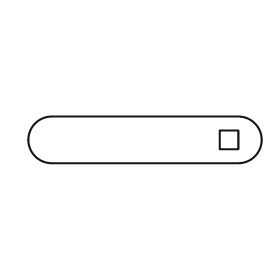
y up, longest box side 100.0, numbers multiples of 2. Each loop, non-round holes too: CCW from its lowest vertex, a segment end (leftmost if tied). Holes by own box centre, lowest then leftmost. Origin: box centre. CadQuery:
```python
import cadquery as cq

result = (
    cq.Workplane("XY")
    .moveTo(-40.0, -10.0)
    .lineTo(40.0, -10.0)
    .threePointArc((50.0, 0.0), (40.0, 10.0))
    .lineTo(-40.0, 10.0)
    .threePointArc((-50.0, 0.0), (-40.0, -10.0))
    .close()
    .moveTo(32.0, -4.0)
    .lineTo(40.0, -4.0)
    .lineTo(40.0, 4.0)
    .lineTo(32.0, 4.0)
    .close()
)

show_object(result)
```